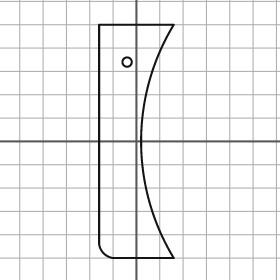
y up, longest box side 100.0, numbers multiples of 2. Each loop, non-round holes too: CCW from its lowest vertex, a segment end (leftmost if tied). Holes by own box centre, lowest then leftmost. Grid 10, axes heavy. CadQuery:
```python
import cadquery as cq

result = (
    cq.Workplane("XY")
    .moveTo(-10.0, -50.0)
    .lineTo(16.0, -50.0)
    .threePointArc((2.0, 0.0), (16.0, 50.0))
    .lineTo(-16.0, 50.0)
    .lineTo(-16.0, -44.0)
    .threePointArc((-14.0, -48.0), (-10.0, -50.0))
    .close()
    .moveTo(-4.0, 34.0)
    .circle(2.0)
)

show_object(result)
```